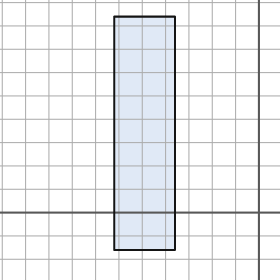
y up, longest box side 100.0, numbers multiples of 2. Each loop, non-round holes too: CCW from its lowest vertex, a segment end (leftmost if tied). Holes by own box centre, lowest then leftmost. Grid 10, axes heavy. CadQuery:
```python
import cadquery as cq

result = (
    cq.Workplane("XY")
    .moveTo(-62.0, -16.0)
    .lineTo(-36.0, -16.0)
    .lineTo(-36.0, 84.0)
    .lineTo(-62.0, 84.0)
    .close()
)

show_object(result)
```